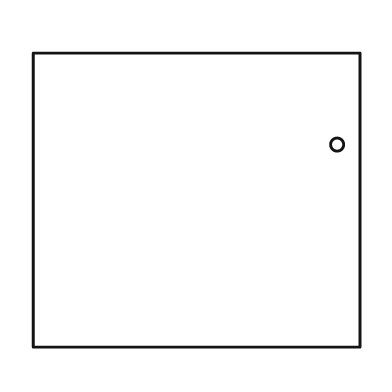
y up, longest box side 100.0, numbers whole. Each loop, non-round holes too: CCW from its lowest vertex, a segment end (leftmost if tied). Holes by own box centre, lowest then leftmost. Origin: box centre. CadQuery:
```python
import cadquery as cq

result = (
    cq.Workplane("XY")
    .moveTo(-50.0, -45.0)
    .lineTo(50.0, -45.0)
    .lineTo(50.0, 45.0)
    .lineTo(-50.0, 45.0)
    .close()
    .moveTo(43.0, 17.0)
    .circle(2.0)
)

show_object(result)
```